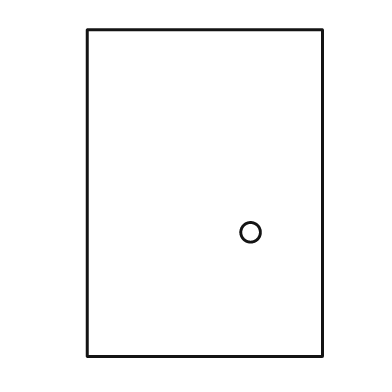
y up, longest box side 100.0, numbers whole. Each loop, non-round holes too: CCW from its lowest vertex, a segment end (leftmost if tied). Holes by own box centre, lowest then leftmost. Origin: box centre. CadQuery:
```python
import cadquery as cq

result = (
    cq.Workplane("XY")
    .moveTo(-36.0, -50.0)
    .lineTo(36.0, -50.0)
    .lineTo(36.0, 50.0)
    .lineTo(-36.0, 50.0)
    .close()
    .moveTo(14.0, -12.0)
    .circle(3.0)
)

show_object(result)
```